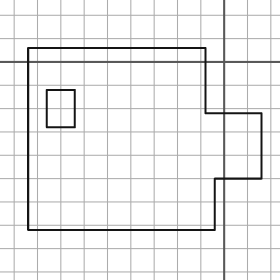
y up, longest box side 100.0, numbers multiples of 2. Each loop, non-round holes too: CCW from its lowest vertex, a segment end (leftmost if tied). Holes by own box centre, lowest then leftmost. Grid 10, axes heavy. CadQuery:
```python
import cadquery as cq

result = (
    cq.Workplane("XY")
    .moveTo(-84.0, -72.0)
    .lineTo(-4.0, -72.0)
    .lineTo(-4.0, -50.0)
    .lineTo(16.0, -50.0)
    .lineTo(16.0, -22.0)
    .lineTo(-8.0, -22.0)
    .lineTo(-8.0, 6.0)
    .lineTo(-84.0, 6.0)
    .close()
    .moveTo(-76.0, -28.0)
    .lineTo(-64.0, -28.0)
    .lineTo(-64.0, -12.0)
    .lineTo(-76.0, -12.0)
    .close()
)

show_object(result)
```